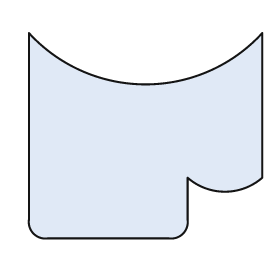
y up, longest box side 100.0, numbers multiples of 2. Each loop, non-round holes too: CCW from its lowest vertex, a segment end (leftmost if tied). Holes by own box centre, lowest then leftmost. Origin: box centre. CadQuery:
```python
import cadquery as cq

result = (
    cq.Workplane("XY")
    .moveTo(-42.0, -44.0)
    .lineTo(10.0, -44.0)
    .threePointArc((16.0, -42.0), (18.0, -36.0))
    .lineTo(18.0, -18.0)
    .threePointArc((34.0, -24.0), (50.0, -18.0))
    .lineTo(50.0, 44.0)
    .threePointArc((0.0, 22.0), (-50.0, 44.0))
    .lineTo(-50.0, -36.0)
    .threePointArc((-48.0, -42.0), (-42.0, -44.0))
    .close()
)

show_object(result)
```